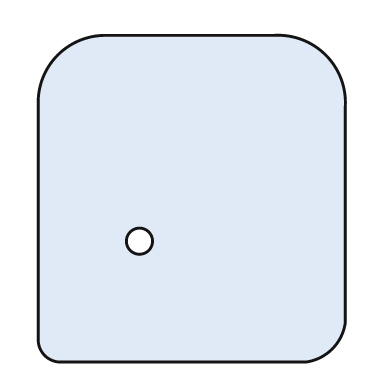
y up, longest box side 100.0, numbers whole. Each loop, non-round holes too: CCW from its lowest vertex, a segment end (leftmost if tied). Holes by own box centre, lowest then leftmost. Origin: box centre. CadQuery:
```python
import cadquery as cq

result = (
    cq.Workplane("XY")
    .moveTo(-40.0, -50.0)
    .lineTo(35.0, -50.0)
    .threePointArc((43.0, -46.0), (47.0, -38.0))
    .lineTo(47.0, 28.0)
    .threePointArc((41.0, 44.0), (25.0, 50.0))
    .lineTo(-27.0, 50.0)
    .threePointArc((-41.0, 44.0), (-47.0, 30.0))
    .lineTo(-47.0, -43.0)
    .threePointArc((-45.0, -48.0), (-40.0, -50.0))
    .close()
    .moveTo(-16.0, -13.0)
    .circle(4.0)
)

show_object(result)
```